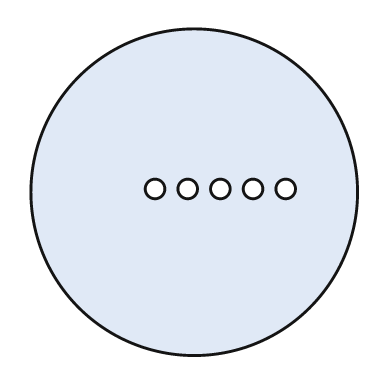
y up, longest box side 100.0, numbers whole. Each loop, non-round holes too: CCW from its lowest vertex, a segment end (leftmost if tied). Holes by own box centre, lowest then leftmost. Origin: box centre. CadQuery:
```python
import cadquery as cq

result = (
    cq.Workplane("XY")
    .moveTo(0.0, 0.0)
    .circle(50.0)
    .moveTo(-12.0, 1.0)
    .circle(3.0)
    .moveTo(-2.0, 1.0)
    .circle(3.0)
    .moveTo(8.0, 1.0)
    .circle(3.0)
    .moveTo(18.0, 1.0)
    .circle(3.0)
    .moveTo(28.0, 1.0)
    .circle(3.0)
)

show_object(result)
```